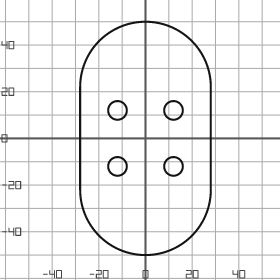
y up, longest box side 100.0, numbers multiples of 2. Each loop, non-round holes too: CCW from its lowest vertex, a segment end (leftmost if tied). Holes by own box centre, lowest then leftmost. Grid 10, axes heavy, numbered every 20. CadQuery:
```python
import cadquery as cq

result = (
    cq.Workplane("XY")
    .moveTo(-28.0, -22.0)
    .threePointArc((0.0, -50.0), (28.0, -22.0))
    .lineTo(28.0, 22.0)
    .threePointArc((0.0, 50.0), (-28.0, 22.0))
    .close()
    .moveTo(-12.0, -12.0)
    .circle(4.0)
    .moveTo(12.0, -12.0)
    .circle(4.0)
    .moveTo(-12.0, 12.0)
    .circle(4.0)
    .moveTo(12.0, 12.0)
    .circle(4.0)
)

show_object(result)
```